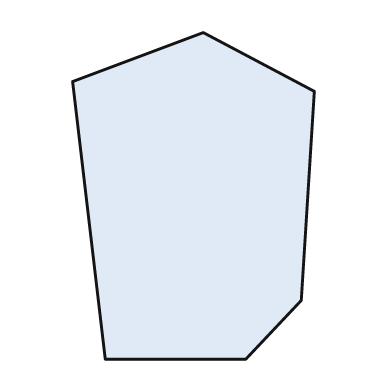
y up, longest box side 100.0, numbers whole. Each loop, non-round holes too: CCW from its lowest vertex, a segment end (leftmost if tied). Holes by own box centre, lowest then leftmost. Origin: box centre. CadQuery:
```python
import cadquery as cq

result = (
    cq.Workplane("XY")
    .moveTo(-27.0, -50.0)
    .lineTo(16.0, -50.0)
    .lineTo(33.0, -32.0)
    .lineTo(37.0, 32.0)
    .lineTo(3.0, 50.0)
    .lineTo(-37.0, 35.0)
    .close()
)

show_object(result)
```